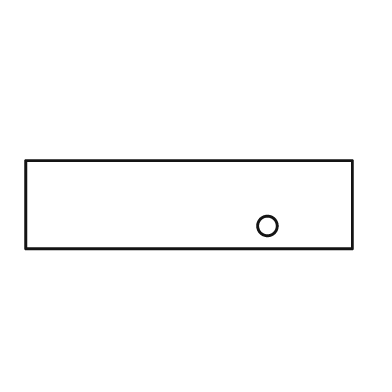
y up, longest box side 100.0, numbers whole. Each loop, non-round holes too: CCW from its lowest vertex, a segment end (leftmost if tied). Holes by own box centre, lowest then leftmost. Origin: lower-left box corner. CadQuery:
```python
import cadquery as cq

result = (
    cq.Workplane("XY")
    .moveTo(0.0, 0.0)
    .lineTo(100.0, 0.0)
    .lineTo(100.0, 27.0)
    .lineTo(0.0, 27.0)
    .close()
    .moveTo(74.0, 7.0)
    .circle(3.0)
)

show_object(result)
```